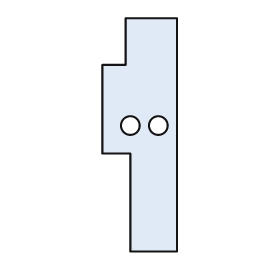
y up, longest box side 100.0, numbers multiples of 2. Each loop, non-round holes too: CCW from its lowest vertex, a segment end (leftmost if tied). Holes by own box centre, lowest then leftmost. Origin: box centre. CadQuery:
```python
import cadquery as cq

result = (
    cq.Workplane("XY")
    .moveTo(-4.0, -50.0)
    .lineTo(16.0, -50.0)
    .lineTo(16.0, 50.0)
    .lineTo(-6.0, 50.0)
    .lineTo(-6.0, 30.0)
    .lineTo(-16.0, 30.0)
    .lineTo(-16.0, -8.0)
    .lineTo(-4.0, -8.0)
    .close()
    .moveTo(-4.0, 4.0)
    .circle(4.0)
    .moveTo(8.0, 4.0)
    .circle(4.0)
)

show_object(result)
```